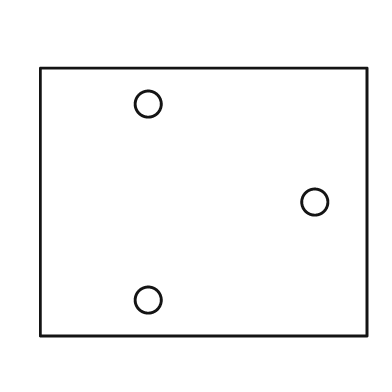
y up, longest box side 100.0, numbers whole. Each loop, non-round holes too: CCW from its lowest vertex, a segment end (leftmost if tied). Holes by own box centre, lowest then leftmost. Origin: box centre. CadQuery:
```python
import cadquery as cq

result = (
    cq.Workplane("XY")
    .moveTo(-50.0, -41.0)
    .lineTo(50.0, -41.0)
    .lineTo(50.0, 41.0)
    .lineTo(-50.0, 41.0)
    .close()
    .moveTo(-17.0, -30.0)
    .circle(4.0)
    .moveTo(34.0, 0.0)
    .circle(4.0)
    .moveTo(-17.0, 30.0)
    .circle(4.0)
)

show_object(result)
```